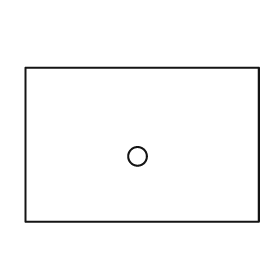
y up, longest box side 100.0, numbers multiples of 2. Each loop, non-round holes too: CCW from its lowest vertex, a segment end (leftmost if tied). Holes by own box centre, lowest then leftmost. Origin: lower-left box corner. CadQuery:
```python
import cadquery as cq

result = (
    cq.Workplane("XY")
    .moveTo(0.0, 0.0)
    .lineTo(100.0, 0.0)
    .lineTo(100.0, 66.0)
    .lineTo(0.0, 66.0)
    .close()
    .moveTo(48.0, 28.0)
    .circle(4.0)
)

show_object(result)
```